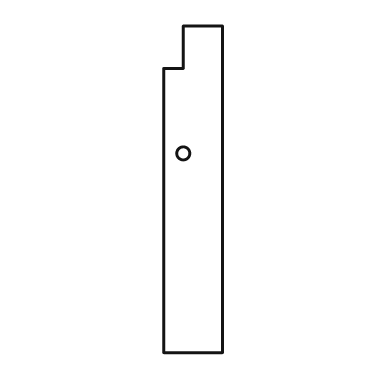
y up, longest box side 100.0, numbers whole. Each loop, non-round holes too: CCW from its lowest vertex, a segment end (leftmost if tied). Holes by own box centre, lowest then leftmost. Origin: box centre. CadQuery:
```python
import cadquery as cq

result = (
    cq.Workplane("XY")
    .moveTo(-9.0, -50.0)
    .lineTo(9.0, -50.0)
    .lineTo(9.0, 50.0)
    .lineTo(-3.0, 50.0)
    .lineTo(-3.0, 37.0)
    .lineTo(-9.0, 37.0)
    .close()
    .moveTo(-3.0, 11.0)
    .circle(2.0)
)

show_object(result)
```